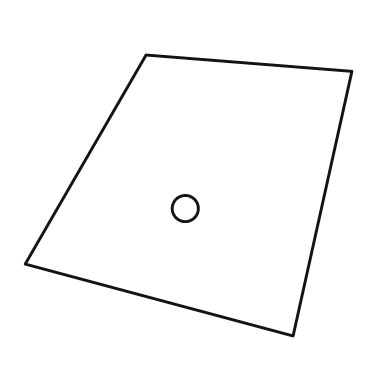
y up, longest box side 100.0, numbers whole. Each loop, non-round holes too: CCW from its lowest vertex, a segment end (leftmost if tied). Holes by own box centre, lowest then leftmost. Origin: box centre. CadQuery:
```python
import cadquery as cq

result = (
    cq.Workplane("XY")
    .moveTo(32.0, -43.0)
    .lineTo(50.0, 38.0)
    .lineTo(-13.0, 43.0)
    .lineTo(-50.0, -21.0)
    .close()
    .moveTo(-1.0, -4.0)
    .circle(4.0)
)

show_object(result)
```